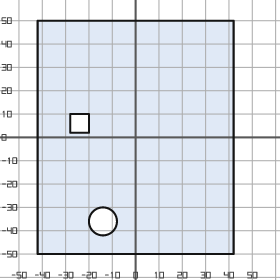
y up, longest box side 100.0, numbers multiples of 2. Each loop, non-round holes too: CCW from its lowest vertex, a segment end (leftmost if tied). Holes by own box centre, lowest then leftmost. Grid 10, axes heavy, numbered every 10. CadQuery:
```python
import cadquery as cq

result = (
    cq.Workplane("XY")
    .moveTo(-42.0, -50.0)
    .lineTo(42.0, -50.0)
    .lineTo(42.0, 50.0)
    .lineTo(-42.0, 50.0)
    .close()
    .moveTo(-14.0, -36.0)
    .circle(6.0)
    .moveTo(-28.0, 2.0)
    .lineTo(-20.0, 2.0)
    .lineTo(-20.0, 10.0)
    .lineTo(-28.0, 10.0)
    .close()
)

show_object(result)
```